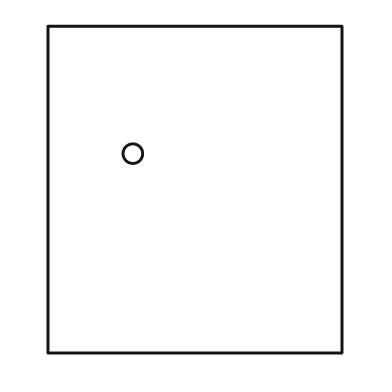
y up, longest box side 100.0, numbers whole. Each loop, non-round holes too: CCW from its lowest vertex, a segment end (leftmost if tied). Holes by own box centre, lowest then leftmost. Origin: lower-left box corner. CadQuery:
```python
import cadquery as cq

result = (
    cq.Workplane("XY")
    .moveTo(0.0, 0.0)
    .lineTo(90.0, 0.0)
    .lineTo(90.0, 100.0)
    .lineTo(0.0, 100.0)
    .close()
    .moveTo(26.0, 61.0)
    .circle(3.0)
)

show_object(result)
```